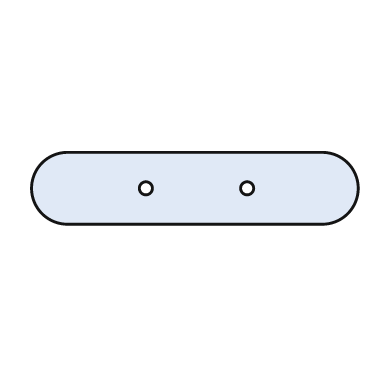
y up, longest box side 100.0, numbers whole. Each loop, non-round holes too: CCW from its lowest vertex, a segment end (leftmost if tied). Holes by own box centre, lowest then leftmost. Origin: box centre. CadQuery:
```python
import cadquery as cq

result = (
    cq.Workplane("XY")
    .moveTo(-39.0, -11.0)
    .lineTo(39.0, -11.0)
    .threePointArc((50.0, 0.0), (39.0, 11.0))
    .lineTo(-39.0, 11.0)
    .threePointArc((-50.0, 0.0), (-39.0, -11.0))
    .close()
    .moveTo(-15.0, 0.0)
    .circle(2.0)
    .moveTo(16.0, 0.0)
    .circle(2.0)
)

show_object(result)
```